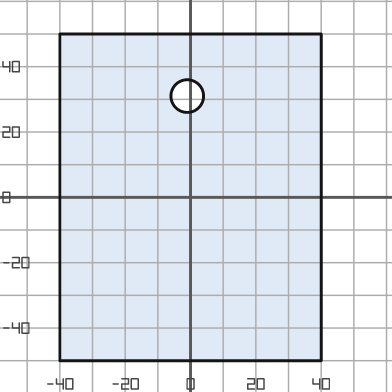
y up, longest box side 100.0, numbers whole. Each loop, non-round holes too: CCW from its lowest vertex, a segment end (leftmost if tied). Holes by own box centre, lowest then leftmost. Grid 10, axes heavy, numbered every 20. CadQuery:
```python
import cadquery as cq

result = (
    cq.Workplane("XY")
    .moveTo(-40.0, -50.0)
    .lineTo(40.0, -50.0)
    .lineTo(40.0, 50.0)
    .lineTo(-40.0, 50.0)
    .close()
    .moveTo(-1.0, 31.0)
    .circle(5.0)
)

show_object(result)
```